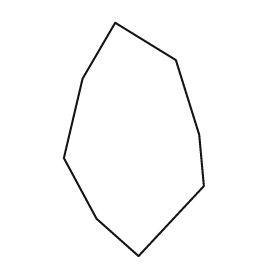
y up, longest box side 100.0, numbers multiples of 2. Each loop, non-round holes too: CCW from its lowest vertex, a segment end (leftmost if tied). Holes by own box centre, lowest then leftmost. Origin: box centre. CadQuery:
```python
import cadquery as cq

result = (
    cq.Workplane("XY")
    .moveTo(2.0, -50.0)
    .lineTo(30.0, -20.0)
    .lineTo(28.0, 2.0)
    .lineTo(18.0, 34.0)
    .lineTo(-8.0, 50.0)
    .lineTo(-22.0, 26.0)
    .lineTo(-30.0, -8.0)
    .lineTo(-16.0, -34.0)
    .close()
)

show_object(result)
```